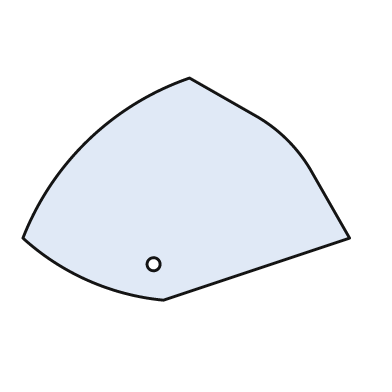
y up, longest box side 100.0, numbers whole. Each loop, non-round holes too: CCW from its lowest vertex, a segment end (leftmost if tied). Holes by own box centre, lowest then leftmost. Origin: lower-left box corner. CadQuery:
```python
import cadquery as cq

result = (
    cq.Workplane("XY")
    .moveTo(43.0, 0.0)
    .lineTo(100.0, 19.0)
    .lineTo(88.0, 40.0)
    .threePointArc((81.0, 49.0), (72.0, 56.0))
    .lineTo(51.0, 68.0)
    .threePointArc((20.0, 49.0), (0.0, 19.0))
    .threePointArc((20.0, 6.0), (43.0, 0.0))
    .close()
    .moveTo(40.0, 11.0)
    .circle(2.0)
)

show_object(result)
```